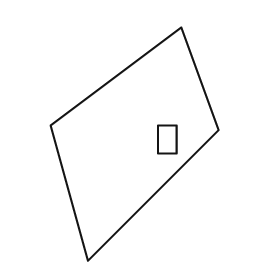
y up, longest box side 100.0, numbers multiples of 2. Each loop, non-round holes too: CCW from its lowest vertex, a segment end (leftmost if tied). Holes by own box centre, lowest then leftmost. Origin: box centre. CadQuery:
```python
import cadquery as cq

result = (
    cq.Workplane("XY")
    .moveTo(-20.0, -50.0)
    .lineTo(36.0, 6.0)
    .lineTo(20.0, 50.0)
    .lineTo(-36.0, 8.0)
    .close()
    .moveTo(10.0, -4.0)
    .lineTo(18.0, -4.0)
    .lineTo(18.0, 8.0)
    .lineTo(10.0, 8.0)
    .close()
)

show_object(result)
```